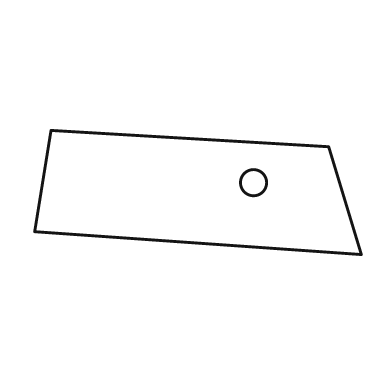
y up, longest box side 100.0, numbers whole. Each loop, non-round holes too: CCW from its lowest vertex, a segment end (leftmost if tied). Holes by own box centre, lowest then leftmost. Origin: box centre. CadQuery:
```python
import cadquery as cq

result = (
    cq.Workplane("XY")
    .moveTo(50.0, -19.0)
    .lineTo(40.0, 14.0)
    .lineTo(-45.0, 19.0)
    .lineTo(-50.0, -12.0)
    .close()
    .moveTo(17.0, 3.0)
    .circle(4.0)
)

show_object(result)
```